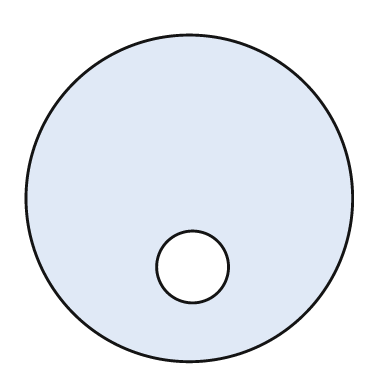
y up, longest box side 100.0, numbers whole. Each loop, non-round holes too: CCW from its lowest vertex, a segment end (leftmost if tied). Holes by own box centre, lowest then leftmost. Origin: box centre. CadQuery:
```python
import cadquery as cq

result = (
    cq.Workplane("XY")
    .moveTo(0.0, 0.0)
    .circle(50.0)
    .moveTo(1.0, -21.0)
    .circle(11.0)
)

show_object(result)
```